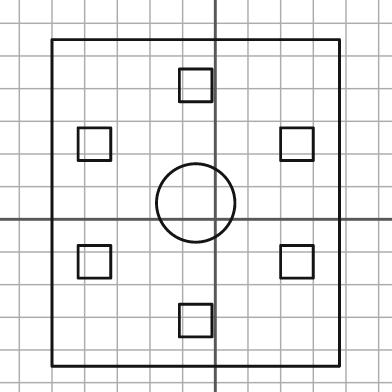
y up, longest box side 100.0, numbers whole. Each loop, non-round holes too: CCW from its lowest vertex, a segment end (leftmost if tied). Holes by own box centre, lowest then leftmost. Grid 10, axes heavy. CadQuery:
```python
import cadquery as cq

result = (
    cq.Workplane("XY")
    .moveTo(-50.0, -45.0)
    .lineTo(38.0, -45.0)
    .lineTo(38.0, 55.0)
    .lineTo(-50.0, 55.0)
    .close()
    .moveTo(-11.0, -36.0)
    .lineTo(-1.0, -36.0)
    .lineTo(-1.0, -26.0)
    .lineTo(-11.0, -26.0)
    .close()
    .moveTo(-42.0, -18.0)
    .lineTo(-32.0, -18.0)
    .lineTo(-32.0, -8.0)
    .lineTo(-42.0, -8.0)
    .close()
    .moveTo(20.0, -18.0)
    .lineTo(30.0, -18.0)
    .lineTo(30.0, -8.0)
    .lineTo(20.0, -8.0)
    .close()
    .moveTo(-6.0, 5.0)
    .circle(12.0)
    .moveTo(-42.0, 18.0)
    .lineTo(-32.0, 18.0)
    .lineTo(-32.0, 28.0)
    .lineTo(-42.0, 28.0)
    .close()
    .moveTo(20.0, 18.0)
    .lineTo(30.0, 18.0)
    .lineTo(30.0, 28.0)
    .lineTo(20.0, 28.0)
    .close()
    .moveTo(-11.0, 36.0)
    .lineTo(-1.0, 36.0)
    .lineTo(-1.0, 46.0)
    .lineTo(-11.0, 46.0)
    .close()
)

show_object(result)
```